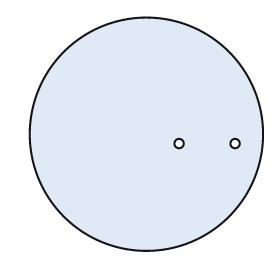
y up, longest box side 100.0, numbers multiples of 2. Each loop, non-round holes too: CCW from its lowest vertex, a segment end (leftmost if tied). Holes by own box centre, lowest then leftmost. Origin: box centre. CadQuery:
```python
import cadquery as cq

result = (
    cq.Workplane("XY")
    .moveTo(0.0, 0.0)
    .circle(50.0)
    .moveTo(14.0, -4.0)
    .circle(2.0)
    .moveTo(38.0, -4.0)
    .circle(2.0)
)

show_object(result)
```